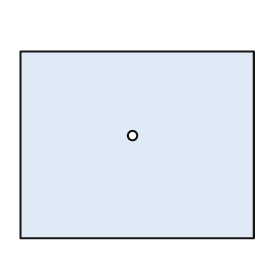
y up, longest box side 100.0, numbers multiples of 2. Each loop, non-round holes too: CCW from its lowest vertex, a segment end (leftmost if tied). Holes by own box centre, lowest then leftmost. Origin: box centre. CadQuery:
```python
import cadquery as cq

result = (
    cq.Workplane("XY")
    .moveTo(-50.0, -40.0)
    .lineTo(50.0, -40.0)
    .lineTo(50.0, 40.0)
    .lineTo(-50.0, 40.0)
    .close()
    .moveTo(-2.0, 4.0)
    .circle(2.0)
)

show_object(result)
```